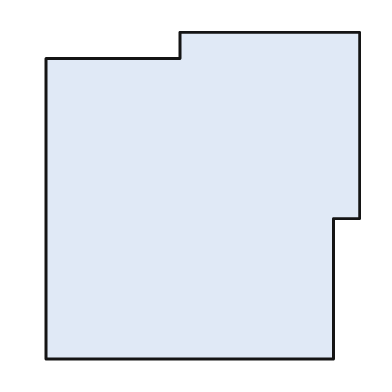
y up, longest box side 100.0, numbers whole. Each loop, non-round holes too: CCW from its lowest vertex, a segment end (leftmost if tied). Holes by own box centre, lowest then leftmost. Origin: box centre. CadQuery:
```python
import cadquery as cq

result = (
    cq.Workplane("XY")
    .moveTo(-48.0, -50.0)
    .lineTo(40.0, -50.0)
    .lineTo(40.0, -7.0)
    .lineTo(48.0, -7.0)
    .lineTo(48.0, 50.0)
    .lineTo(-7.0, 50.0)
    .lineTo(-7.0, 42.0)
    .lineTo(-48.0, 42.0)
    .close()
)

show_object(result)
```